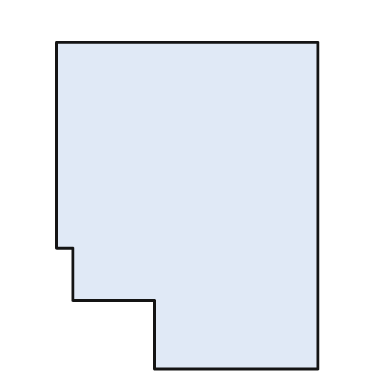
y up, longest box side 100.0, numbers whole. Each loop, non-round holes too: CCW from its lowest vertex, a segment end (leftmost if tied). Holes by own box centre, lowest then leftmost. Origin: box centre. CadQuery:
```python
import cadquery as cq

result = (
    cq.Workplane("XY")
    .moveTo(-10.0, -50.0)
    .lineTo(40.0, -50.0)
    .lineTo(40.0, 50.0)
    .lineTo(-40.0, 50.0)
    .lineTo(-40.0, -13.0)
    .lineTo(-35.0, -13.0)
    .lineTo(-35.0, -29.0)
    .lineTo(-10.0, -29.0)
    .close()
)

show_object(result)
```